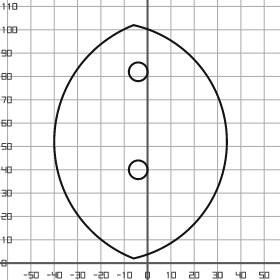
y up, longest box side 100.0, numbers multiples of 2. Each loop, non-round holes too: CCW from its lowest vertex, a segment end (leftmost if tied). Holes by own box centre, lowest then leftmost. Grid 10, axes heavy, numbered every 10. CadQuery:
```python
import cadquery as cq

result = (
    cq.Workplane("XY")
    .moveTo(-6.0, 2.0)
    .threePointArc((34.0, 52.0), (-6.0, 102.0))
    .threePointArc((-40.0, 52.0), (-6.0, 2.0))
    .close()
    .moveTo(-4.0, 40.0)
    .circle(4.0)
    .moveTo(-4.0, 82.0)
    .circle(4.0)
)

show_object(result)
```